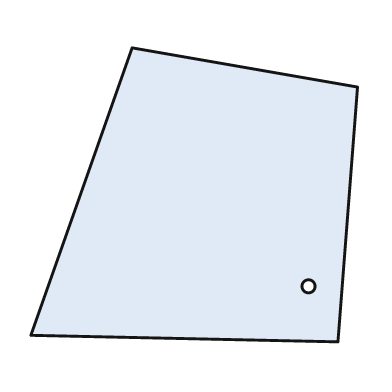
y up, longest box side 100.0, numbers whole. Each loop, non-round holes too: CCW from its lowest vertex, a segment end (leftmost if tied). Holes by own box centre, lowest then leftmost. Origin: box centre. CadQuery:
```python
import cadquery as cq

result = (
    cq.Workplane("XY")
    .moveTo(44.0, -45.0)
    .lineTo(50.0, 33.0)
    .lineTo(-19.0, 45.0)
    .lineTo(-50.0, -43.0)
    .close()
    .moveTo(35.0, -28.0)
    .circle(2.0)
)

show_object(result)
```